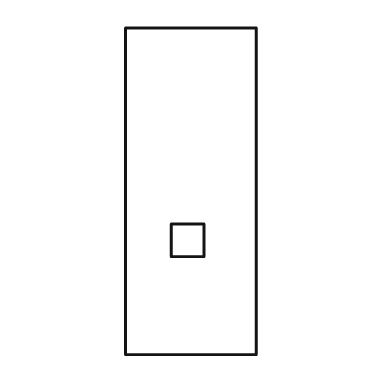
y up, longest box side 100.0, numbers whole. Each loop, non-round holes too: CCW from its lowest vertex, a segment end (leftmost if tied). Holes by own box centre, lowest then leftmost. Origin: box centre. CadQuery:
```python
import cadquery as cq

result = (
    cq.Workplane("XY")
    .moveTo(-20.0, -50.0)
    .lineTo(20.0, -50.0)
    .lineTo(20.0, 50.0)
    .lineTo(-20.0, 50.0)
    .close()
    .moveTo(-6.0, -20.0)
    .lineTo(4.0, -20.0)
    .lineTo(4.0, -10.0)
    .lineTo(-6.0, -10.0)
    .close()
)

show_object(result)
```